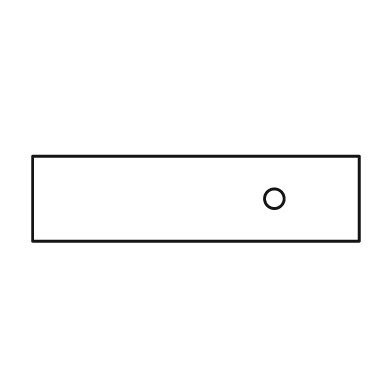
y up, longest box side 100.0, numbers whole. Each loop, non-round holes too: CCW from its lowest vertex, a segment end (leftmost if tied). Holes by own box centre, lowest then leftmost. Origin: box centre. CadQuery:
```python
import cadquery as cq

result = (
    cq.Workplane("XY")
    .moveTo(-50.0, -13.0)
    .lineTo(50.0, -13.0)
    .lineTo(50.0, 13.0)
    .lineTo(-50.0, 13.0)
    .close()
    .moveTo(24.0, 0.0)
    .circle(3.0)
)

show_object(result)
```